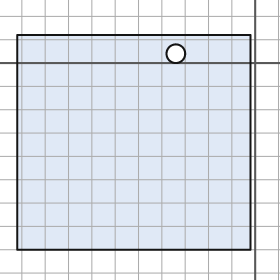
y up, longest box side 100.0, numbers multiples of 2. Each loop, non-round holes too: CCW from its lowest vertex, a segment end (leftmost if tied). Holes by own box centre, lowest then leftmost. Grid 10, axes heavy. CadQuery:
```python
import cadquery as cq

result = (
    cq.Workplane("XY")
    .moveTo(-102.0, -80.0)
    .lineTo(-2.0, -80.0)
    .lineTo(-2.0, 12.0)
    .lineTo(-102.0, 12.0)
    .close()
    .moveTo(-34.0, 4.0)
    .circle(4.0)
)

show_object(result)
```